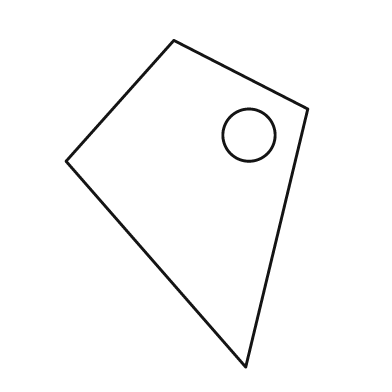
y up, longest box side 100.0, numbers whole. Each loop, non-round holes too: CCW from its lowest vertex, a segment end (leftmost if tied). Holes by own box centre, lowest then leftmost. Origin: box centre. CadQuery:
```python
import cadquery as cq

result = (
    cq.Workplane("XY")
    .moveTo(18.0, -50.0)
    .lineTo(37.0, 29.0)
    .lineTo(-4.0, 50.0)
    .lineTo(-37.0, 13.0)
    .close()
    .moveTo(19.0, 21.0)
    .circle(8.0)
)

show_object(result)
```